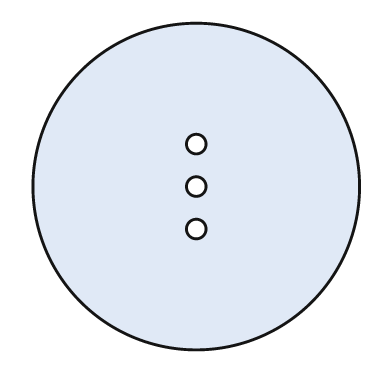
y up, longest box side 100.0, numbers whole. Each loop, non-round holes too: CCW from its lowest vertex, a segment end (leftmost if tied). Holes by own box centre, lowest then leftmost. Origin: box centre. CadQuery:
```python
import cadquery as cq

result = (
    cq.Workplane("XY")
    .moveTo(0.0, 0.0)
    .circle(50.0)
    .moveTo(0.0, -13.0)
    .circle(3.0)
    .moveTo(0.0, 0.0)
    .circle(3.0)
    .moveTo(0.0, 13.0)
    .circle(3.0)
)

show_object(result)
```